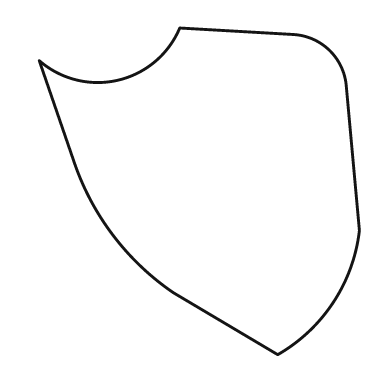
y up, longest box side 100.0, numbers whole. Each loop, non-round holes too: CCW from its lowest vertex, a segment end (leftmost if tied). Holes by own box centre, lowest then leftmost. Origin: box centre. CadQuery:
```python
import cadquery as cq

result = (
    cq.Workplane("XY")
    .moveTo(24.0, -50.0)
    .threePointArc((41.0, -34.0), (49.0, -12.0))
    .lineTo(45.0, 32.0)
    .threePointArc((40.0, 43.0), (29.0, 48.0))
    .lineTo(-6.0, 50.0)
    .threePointArc((-25.0, 34.0), (-49.0, 40.0))
    .lineTo(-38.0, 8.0)
    .threePointArc((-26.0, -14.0), (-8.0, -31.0))
    .close()
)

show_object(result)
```